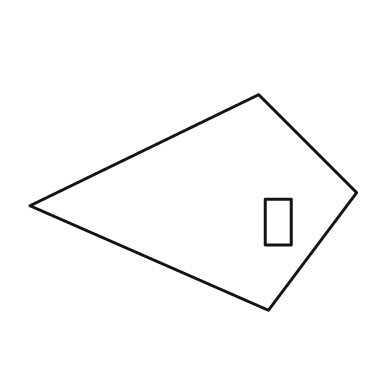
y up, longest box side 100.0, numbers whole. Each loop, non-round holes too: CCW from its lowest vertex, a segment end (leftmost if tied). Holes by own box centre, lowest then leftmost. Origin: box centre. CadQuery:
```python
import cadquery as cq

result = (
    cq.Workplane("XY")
    .moveTo(23.0, -33.0)
    .lineTo(50.0, 3.0)
    .lineTo(20.0, 33.0)
    .lineTo(-50.0, -1.0)
    .close()
    .moveTo(22.0, -13.0)
    .lineTo(30.0, -13.0)
    .lineTo(30.0, 1.0)
    .lineTo(22.0, 1.0)
    .close()
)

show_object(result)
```